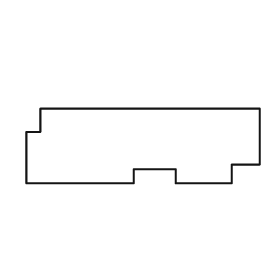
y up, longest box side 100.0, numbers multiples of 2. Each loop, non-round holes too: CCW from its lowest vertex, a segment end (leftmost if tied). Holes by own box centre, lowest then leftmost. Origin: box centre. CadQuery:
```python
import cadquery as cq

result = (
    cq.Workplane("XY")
    .moveTo(-50.0, -16.0)
    .lineTo(-4.0, -16.0)
    .lineTo(-4.0, -10.0)
    .lineTo(14.0, -10.0)
    .lineTo(14.0, -16.0)
    .lineTo(38.0, -16.0)
    .lineTo(38.0, -8.0)
    .lineTo(50.0, -8.0)
    .lineTo(50.0, 16.0)
    .lineTo(-44.0, 16.0)
    .lineTo(-44.0, 6.0)
    .lineTo(-50.0, 6.0)
    .close()
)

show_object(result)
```